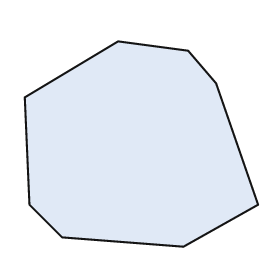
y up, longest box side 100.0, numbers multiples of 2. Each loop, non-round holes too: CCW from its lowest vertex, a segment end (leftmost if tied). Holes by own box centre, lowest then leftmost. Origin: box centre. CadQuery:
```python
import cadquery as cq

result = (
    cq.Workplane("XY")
    .moveTo(18.0, -44.0)
    .lineTo(50.0, -26.0)
    .lineTo(32.0, 26.0)
    .lineTo(20.0, 40.0)
    .lineTo(-10.0, 44.0)
    .lineTo(-50.0, 20.0)
    .lineTo(-48.0, -26.0)
    .lineTo(-34.0, -40.0)
    .close()
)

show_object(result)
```